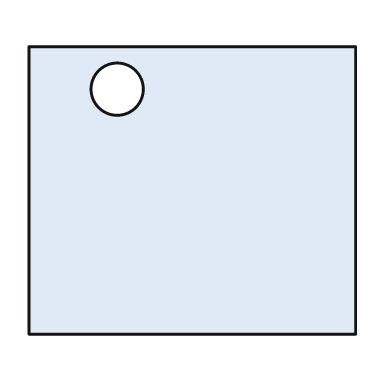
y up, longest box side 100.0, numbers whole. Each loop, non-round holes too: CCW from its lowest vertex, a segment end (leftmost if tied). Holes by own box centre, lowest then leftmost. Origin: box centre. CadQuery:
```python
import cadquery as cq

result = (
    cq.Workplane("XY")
    .moveTo(-50.0, -44.0)
    .lineTo(50.0, -44.0)
    .lineTo(50.0, 44.0)
    .lineTo(-50.0, 44.0)
    .close()
    .moveTo(-23.0, 31.0)
    .circle(8.0)
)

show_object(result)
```